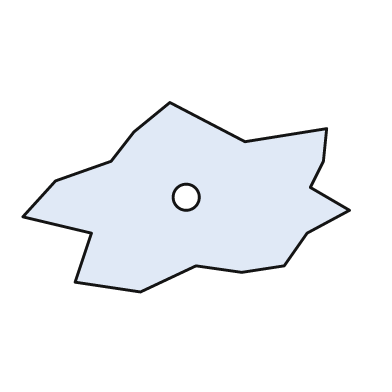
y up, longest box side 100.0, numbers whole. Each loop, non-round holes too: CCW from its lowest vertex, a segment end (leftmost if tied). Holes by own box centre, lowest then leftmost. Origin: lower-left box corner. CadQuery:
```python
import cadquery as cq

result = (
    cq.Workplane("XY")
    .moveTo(36.0, 0.0)
    .lineTo(53.0, 8.0)
    .lineTo(67.0, 6.0)
    .lineTo(80.0, 8.0)
    .lineTo(87.0, 18.0)
    .lineTo(100.0, 25.0)
    .lineTo(88.0, 32.0)
    .lineTo(92.0, 40.0)
    .lineTo(93.0, 50.0)
    .lineTo(68.0, 46.0)
    .lineTo(45.0, 58.0)
    .lineTo(34.0, 49.0)
    .lineTo(27.0, 40.0)
    .lineTo(10.0, 34.0)
    .lineTo(0.0, 23.0)
    .lineTo(21.0, 18.0)
    .lineTo(16.0, 3.0)
    .close()
    .moveTo(50.0, 29.0)
    .circle(4.0)
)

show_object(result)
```